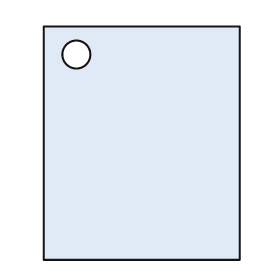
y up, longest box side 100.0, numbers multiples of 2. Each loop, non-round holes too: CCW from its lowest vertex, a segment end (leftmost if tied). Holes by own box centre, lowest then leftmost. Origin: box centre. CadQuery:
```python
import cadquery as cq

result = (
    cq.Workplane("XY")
    .moveTo(-42.0, -50.0)
    .lineTo(42.0, -50.0)
    .lineTo(42.0, 50.0)
    .lineTo(-42.0, 50.0)
    .close()
    .moveTo(-28.0, 38.0)
    .circle(6.0)
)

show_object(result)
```